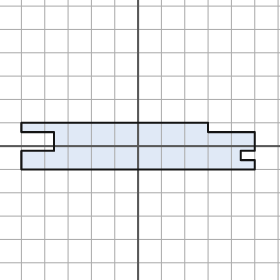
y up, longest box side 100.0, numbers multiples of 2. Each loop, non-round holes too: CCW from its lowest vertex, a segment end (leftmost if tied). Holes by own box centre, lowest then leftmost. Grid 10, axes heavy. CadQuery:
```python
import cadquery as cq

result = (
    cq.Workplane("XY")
    .moveTo(-50.0, -10.0)
    .lineTo(50.0, -10.0)
    .lineTo(50.0, -6.0)
    .lineTo(44.0, -6.0)
    .lineTo(44.0, -2.0)
    .lineTo(50.0, -2.0)
    .lineTo(50.0, 6.0)
    .lineTo(30.0, 6.0)
    .lineTo(30.0, 10.0)
    .lineTo(-50.0, 10.0)
    .lineTo(-50.0, 6.0)
    .lineTo(-36.0, 6.0)
    .lineTo(-36.0, -2.0)
    .lineTo(-50.0, -2.0)
    .close()
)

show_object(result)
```